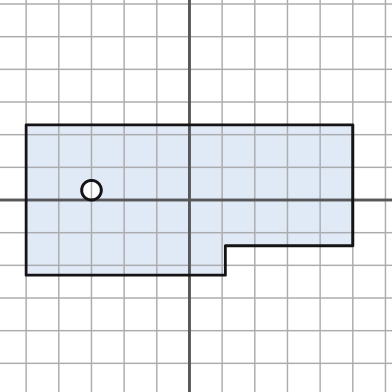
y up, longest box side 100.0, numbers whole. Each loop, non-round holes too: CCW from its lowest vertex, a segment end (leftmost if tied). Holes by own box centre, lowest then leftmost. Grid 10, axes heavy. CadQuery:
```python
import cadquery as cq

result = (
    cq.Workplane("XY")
    .moveTo(-50.0, -23.0)
    .lineTo(11.0, -23.0)
    .lineTo(11.0, -14.0)
    .lineTo(50.0, -14.0)
    .lineTo(50.0, 23.0)
    .lineTo(-50.0, 23.0)
    .close()
    .moveTo(-30.0, 3.0)
    .circle(3.0)
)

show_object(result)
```